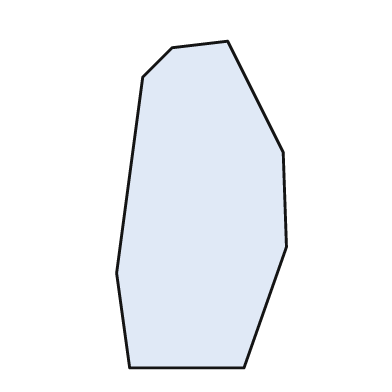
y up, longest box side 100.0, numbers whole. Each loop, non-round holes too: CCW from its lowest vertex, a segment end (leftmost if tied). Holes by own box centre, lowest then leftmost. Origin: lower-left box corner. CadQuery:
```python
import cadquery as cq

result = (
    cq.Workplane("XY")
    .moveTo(4.0, 0.0)
    .lineTo(39.0, 0.0)
    .lineTo(52.0, 37.0)
    .lineTo(51.0, 66.0)
    .lineTo(34.0, 100.0)
    .lineTo(17.0, 98.0)
    .lineTo(8.0, 89.0)
    .lineTo(0.0, 29.0)
    .close()
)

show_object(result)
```